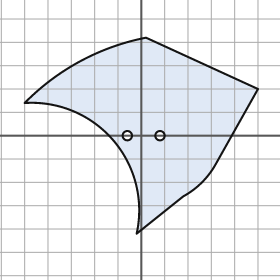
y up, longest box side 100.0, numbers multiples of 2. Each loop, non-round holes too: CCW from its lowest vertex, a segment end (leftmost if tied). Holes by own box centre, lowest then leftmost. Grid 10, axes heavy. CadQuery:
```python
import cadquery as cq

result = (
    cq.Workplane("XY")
    .moveTo(-2.0, -42.0)
    .lineTo(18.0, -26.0)
    .threePointArc((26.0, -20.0), (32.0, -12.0))
    .lineTo(50.0, 20.0)
    .lineTo(2.0, 42.0)
    .threePointArc((-26.0, 32.0), (-50.0, 14.0))
    .threePointArc((-12.0, -2.0), (-2.0, -42.0))
    .close()
    .moveTo(-6.0, 0.0)
    .circle(2.0)
    .moveTo(8.0, 0.0)
    .circle(2.0)
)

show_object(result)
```